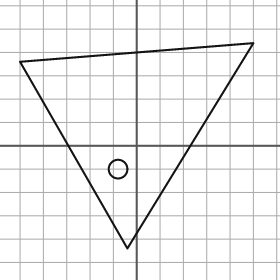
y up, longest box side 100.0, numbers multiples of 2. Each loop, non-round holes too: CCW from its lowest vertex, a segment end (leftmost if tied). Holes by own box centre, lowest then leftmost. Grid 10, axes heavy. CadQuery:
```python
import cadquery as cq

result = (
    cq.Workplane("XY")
    .moveTo(-4.0, -44.0)
    .lineTo(50.0, 44.0)
    .lineTo(-50.0, 36.0)
    .close()
    .moveTo(-8.0, -10.0)
    .circle(4.0)
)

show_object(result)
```